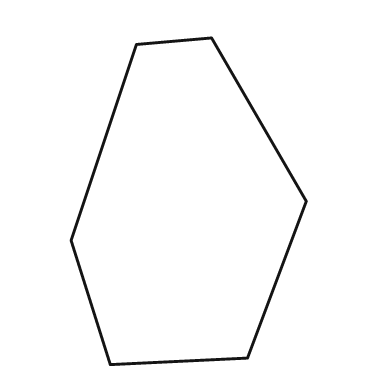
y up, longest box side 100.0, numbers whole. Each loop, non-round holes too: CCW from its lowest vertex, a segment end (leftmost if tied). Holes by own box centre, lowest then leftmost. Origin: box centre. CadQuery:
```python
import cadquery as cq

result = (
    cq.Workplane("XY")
    .moveTo(-24.0, -50.0)
    .lineTo(18.0, -48.0)
    .lineTo(36.0, 0.0)
    .lineTo(7.0, 50.0)
    .lineTo(-16.0, 48.0)
    .lineTo(-36.0, -12.0)
    .close()
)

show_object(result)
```